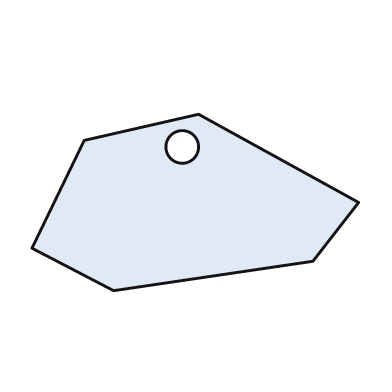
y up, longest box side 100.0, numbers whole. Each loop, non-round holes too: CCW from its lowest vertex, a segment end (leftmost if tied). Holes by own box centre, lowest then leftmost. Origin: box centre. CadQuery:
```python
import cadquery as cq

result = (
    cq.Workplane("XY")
    .moveTo(-25.0, -27.0)
    .lineTo(36.0, -18.0)
    .lineTo(50.0, 0.0)
    .lineTo(1.0, 27.0)
    .lineTo(-34.0, 19.0)
    .lineTo(-50.0, -14.0)
    .close()
    .moveTo(-4.0, 17.0)
    .circle(5.0)
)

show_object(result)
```